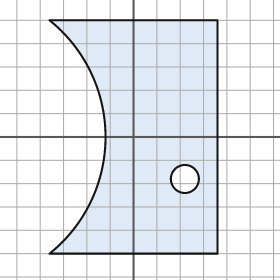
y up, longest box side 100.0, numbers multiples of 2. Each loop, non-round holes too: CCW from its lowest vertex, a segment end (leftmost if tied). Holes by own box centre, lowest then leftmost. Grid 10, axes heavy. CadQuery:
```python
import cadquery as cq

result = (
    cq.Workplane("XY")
    .moveTo(-36.0, -50.0)
    .lineTo(36.0, -50.0)
    .lineTo(36.0, 50.0)
    .lineTo(-36.0, 50.0)
    .threePointArc((-12.0, 0.0), (-36.0, -50.0))
    .close()
    .moveTo(22.0, -18.0)
    .circle(6.0)
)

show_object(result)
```